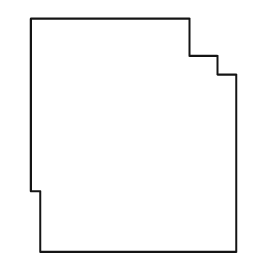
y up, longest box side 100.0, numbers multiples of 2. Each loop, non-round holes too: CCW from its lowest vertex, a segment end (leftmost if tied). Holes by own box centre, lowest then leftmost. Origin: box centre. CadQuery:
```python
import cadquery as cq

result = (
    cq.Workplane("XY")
    .moveTo(-40.0, -50.0)
    .lineTo(44.0, -50.0)
    .lineTo(44.0, 26.0)
    .lineTo(36.0, 26.0)
    .lineTo(36.0, 34.0)
    .lineTo(24.0, 34.0)
    .lineTo(24.0, 50.0)
    .lineTo(-44.0, 50.0)
    .lineTo(-44.0, -24.0)
    .lineTo(-40.0, -24.0)
    .close()
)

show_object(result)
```